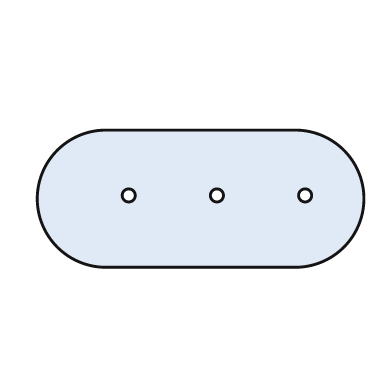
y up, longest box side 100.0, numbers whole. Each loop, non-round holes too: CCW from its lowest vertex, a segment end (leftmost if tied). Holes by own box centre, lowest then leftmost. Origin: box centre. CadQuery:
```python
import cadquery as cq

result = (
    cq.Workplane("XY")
    .moveTo(-29.0, -21.0)
    .lineTo(29.0, -21.0)
    .threePointArc((50.0, 0.0), (29.0, 21.0))
    .lineTo(-29.0, 21.0)
    .threePointArc((-50.0, 0.0), (-29.0, -21.0))
    .close()
    .moveTo(-22.0, 1.0)
    .circle(2.0)
    .moveTo(5.0, 1.0)
    .circle(2.0)
    .moveTo(32.0, 1.0)
    .circle(2.0)
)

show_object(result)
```